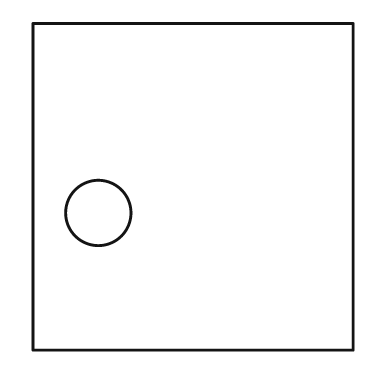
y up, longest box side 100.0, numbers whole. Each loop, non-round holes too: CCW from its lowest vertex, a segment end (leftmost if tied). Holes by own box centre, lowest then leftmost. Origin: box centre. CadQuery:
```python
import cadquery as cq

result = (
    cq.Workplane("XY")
    .moveTo(-49.0, -50.0)
    .lineTo(49.0, -50.0)
    .lineTo(49.0, 50.0)
    .lineTo(-49.0, 50.0)
    .close()
    .moveTo(-29.0, -8.0)
    .circle(10.0)
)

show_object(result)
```